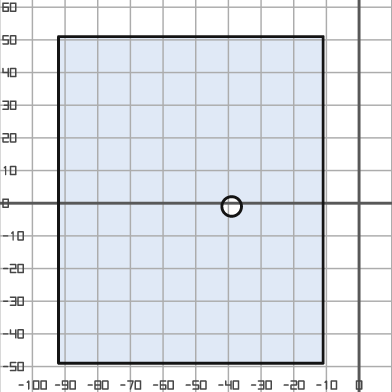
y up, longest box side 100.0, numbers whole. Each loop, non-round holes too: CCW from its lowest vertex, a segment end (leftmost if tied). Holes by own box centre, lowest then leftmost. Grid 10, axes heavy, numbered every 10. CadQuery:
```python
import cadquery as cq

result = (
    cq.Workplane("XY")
    .moveTo(-92.0, -49.0)
    .lineTo(-11.0, -49.0)
    .lineTo(-11.0, 51.0)
    .lineTo(-92.0, 51.0)
    .close()
    .moveTo(-39.0, -1.0)
    .circle(3.0)
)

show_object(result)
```